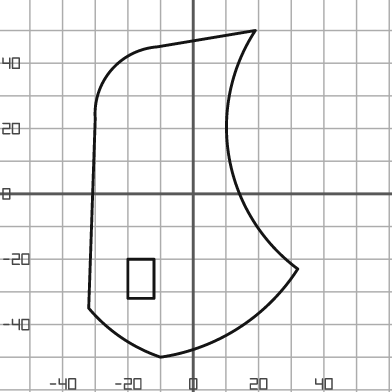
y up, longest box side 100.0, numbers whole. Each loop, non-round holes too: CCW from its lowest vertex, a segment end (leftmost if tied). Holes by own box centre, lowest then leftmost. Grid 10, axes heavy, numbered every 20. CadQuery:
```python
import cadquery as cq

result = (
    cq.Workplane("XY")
    .moveTo(-10.0, -50.0)
    .threePointArc((14.0, -41.0), (32.0, -23.0))
    .threePointArc((11.0, 11.0), (19.0, 50.0))
    .lineTo(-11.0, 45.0)
    .threePointArc((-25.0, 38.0), (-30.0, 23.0))
    .lineTo(-32.0, -35.0)
    .threePointArc((-22.0, -44.0), (-10.0, -50.0))
    .close()
    .moveTo(-20.0, -32.0)
    .lineTo(-12.0, -32.0)
    .lineTo(-12.0, -20.0)
    .lineTo(-20.0, -20.0)
    .close()
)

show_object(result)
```